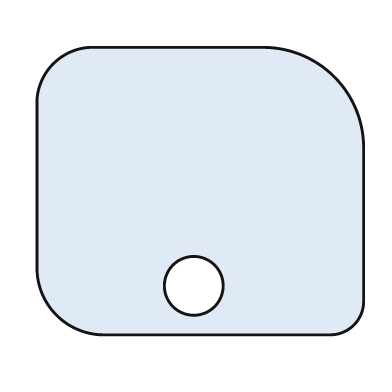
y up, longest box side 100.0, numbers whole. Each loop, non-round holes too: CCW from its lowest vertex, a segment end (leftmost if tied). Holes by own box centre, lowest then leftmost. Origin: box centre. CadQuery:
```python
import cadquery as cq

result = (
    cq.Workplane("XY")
    .moveTo(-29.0, -44.0)
    .lineTo(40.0, -44.0)
    .threePointArc((47.0, -41.0), (50.0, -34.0))
    .lineTo(50.0, 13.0)
    .threePointArc((41.0, 35.0), (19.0, 44.0))
    .lineTo(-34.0, 44.0)
    .threePointArc((-45.0, 39.0), (-50.0, 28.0))
    .lineTo(-50.0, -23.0)
    .threePointArc((-44.0, -38.0), (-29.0, -44.0))
    .close()
    .moveTo(-2.0, -29.0)
    .circle(9.0)
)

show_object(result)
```